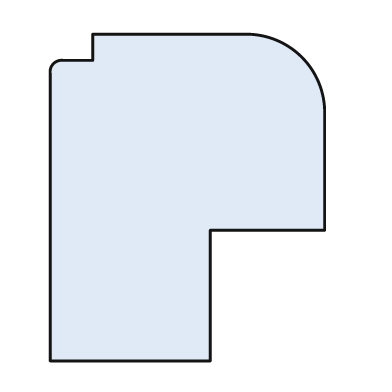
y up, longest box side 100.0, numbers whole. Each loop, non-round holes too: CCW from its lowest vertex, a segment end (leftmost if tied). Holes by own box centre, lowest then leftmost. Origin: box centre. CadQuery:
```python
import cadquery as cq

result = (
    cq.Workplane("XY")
    .moveTo(-42.0, -50.0)
    .lineTo(7.0, -50.0)
    .lineTo(7.0, -10.0)
    .lineTo(42.0, -10.0)
    .lineTo(42.0, 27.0)
    .threePointArc((35.0, 43.0), (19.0, 50.0))
    .lineTo(-29.0, 50.0)
    .lineTo(-29.0, 42.0)
    .lineTo(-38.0, 42.0)
    .threePointArc((-41.0, 41.0), (-42.0, 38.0))
    .close()
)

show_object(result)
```